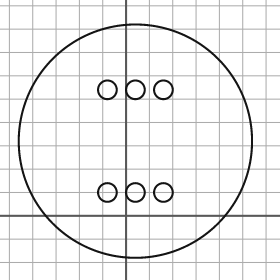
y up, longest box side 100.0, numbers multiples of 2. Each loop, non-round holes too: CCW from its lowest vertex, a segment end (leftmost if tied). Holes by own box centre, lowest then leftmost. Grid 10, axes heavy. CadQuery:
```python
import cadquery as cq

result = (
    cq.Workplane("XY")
    .moveTo(4.0, 32.0)
    .circle(50.0)
    .moveTo(-8.0, 10.0)
    .circle(4.0)
    .moveTo(4.0, 10.0)
    .circle(4.0)
    .moveTo(16.0, 10.0)
    .circle(4.0)
    .moveTo(-8.0, 54.0)
    .circle(4.0)
    .moveTo(4.0, 54.0)
    .circle(4.0)
    .moveTo(16.0, 54.0)
    .circle(4.0)
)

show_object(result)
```